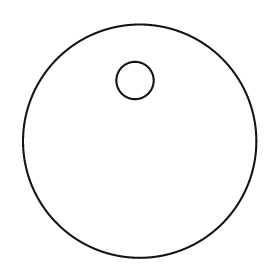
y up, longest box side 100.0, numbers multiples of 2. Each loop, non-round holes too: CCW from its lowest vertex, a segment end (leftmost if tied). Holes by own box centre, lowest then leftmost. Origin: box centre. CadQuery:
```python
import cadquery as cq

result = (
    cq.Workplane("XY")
    .moveTo(0.0, 0.0)
    .circle(50.0)
    .moveTo(-2.0, 26.0)
    .circle(8.0)
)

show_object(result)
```